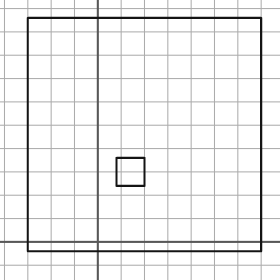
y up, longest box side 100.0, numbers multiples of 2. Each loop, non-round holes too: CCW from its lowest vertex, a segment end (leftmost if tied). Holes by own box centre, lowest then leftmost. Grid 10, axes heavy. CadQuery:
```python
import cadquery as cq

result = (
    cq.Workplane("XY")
    .moveTo(-30.0, -4.0)
    .lineTo(70.0, -4.0)
    .lineTo(70.0, 96.0)
    .lineTo(-30.0, 96.0)
    .close()
    .moveTo(8.0, 24.0)
    .lineTo(20.0, 24.0)
    .lineTo(20.0, 36.0)
    .lineTo(8.0, 36.0)
    .close()
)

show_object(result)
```